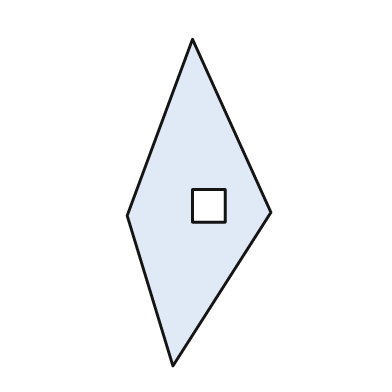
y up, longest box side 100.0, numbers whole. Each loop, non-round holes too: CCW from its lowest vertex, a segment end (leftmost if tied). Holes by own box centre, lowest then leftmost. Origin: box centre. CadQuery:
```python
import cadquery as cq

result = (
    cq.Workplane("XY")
    .moveTo(-8.0, -50.0)
    .lineTo(22.0, -3.0)
    .lineTo(-2.0, 50.0)
    .lineTo(-22.0, -4.0)
    .close()
    .moveTo(-2.0, -6.0)
    .lineTo(8.0, -6.0)
    .lineTo(8.0, 4.0)
    .lineTo(-2.0, 4.0)
    .close()
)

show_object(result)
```